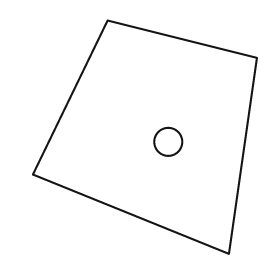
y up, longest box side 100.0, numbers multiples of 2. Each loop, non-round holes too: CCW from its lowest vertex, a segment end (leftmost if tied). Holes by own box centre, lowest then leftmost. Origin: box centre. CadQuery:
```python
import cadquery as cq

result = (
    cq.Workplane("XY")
    .moveTo(36.0, -50.0)
    .lineTo(48.0, 34.0)
    .lineTo(-16.0, 50.0)
    .lineTo(-48.0, -16.0)
    .close()
    .moveTo(10.0, -2.0)
    .circle(6.0)
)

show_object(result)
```